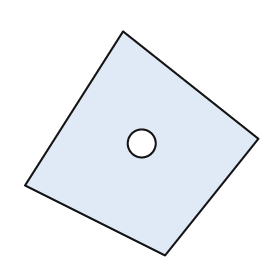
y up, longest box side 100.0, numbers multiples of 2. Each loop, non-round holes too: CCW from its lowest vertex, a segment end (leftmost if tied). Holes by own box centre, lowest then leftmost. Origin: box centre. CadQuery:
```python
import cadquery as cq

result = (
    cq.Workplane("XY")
    .moveTo(10.0, -48.0)
    .lineTo(50.0, 2.0)
    .lineTo(-8.0, 48.0)
    .lineTo(-50.0, -18.0)
    .close()
    .moveTo(0.0, 0.0)
    .circle(6.0)
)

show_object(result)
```